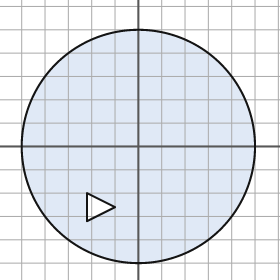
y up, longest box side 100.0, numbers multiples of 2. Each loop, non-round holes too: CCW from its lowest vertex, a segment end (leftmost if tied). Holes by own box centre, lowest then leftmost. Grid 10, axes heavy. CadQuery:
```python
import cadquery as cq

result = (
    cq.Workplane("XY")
    .moveTo(0.0, 0.0)
    .circle(50.0)
    .moveTo(-22.0, -32.0)
    .lineTo(-10.0, -26.0)
    .lineTo(-22.0, -20.0)
    .close()
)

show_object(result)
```